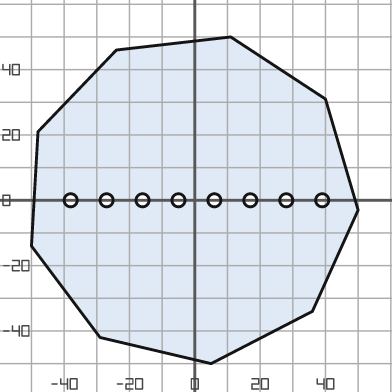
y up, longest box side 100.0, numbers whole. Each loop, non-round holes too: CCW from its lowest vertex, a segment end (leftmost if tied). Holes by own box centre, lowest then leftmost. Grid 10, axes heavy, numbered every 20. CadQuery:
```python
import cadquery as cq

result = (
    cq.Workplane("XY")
    .moveTo(5.0, -50.0)
    .lineTo(36.0, -34.0)
    .lineTo(50.0, -3.0)
    .lineTo(40.0, 31.0)
    .lineTo(11.0, 50.0)
    .lineTo(-24.0, 46.0)
    .lineTo(-48.0, 21.0)
    .lineTo(-50.0, -14.0)
    .lineTo(-29.0, -42.0)
    .close()
    .moveTo(-38.0, 0.0)
    .circle(2.0)
    .moveTo(-27.0, 0.0)
    .circle(2.0)
    .moveTo(-16.0, 0.0)
    .circle(2.0)
    .moveTo(-5.0, 0.0)
    .circle(2.0)
    .moveTo(6.0, 0.0)
    .circle(2.0)
    .moveTo(17.0, 0.0)
    .circle(2.0)
    .moveTo(28.0, 0.0)
    .circle(2.0)
    .moveTo(39.0, 0.0)
    .circle(2.0)
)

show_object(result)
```